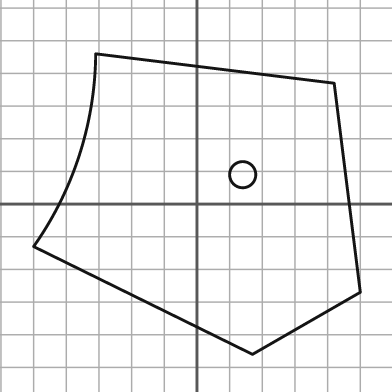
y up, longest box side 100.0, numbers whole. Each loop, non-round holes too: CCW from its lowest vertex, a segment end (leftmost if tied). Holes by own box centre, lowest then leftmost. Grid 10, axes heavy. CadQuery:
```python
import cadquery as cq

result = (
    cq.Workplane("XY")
    .moveTo(17.0, -46.0)
    .lineTo(50.0, -27.0)
    .lineTo(42.0, 37.0)
    .lineTo(-31.0, 46.0)
    .threePointArc((-36.0, 15.0), (-50.0, -13.0))
    .close()
    .moveTo(14.0, 9.0)
    .circle(4.0)
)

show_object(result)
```